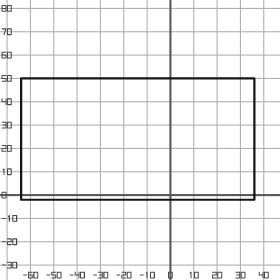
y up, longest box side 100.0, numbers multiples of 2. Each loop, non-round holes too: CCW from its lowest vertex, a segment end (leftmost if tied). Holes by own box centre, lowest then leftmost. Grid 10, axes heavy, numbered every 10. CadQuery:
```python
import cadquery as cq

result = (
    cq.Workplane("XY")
    .moveTo(-64.0, -2.0)
    .lineTo(36.0, -2.0)
    .lineTo(36.0, 50.0)
    .lineTo(-64.0, 50.0)
    .close()
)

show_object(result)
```